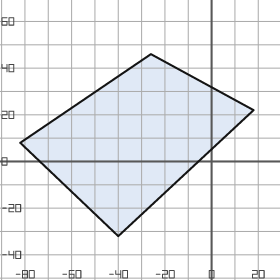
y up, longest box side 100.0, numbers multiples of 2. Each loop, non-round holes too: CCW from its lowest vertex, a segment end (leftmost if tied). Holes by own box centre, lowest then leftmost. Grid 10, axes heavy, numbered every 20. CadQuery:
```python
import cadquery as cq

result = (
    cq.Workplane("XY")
    .moveTo(-40.0, -32.0)
    .lineTo(18.0, 22.0)
    .lineTo(-26.0, 46.0)
    .lineTo(-82.0, 8.0)
    .close()
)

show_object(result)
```